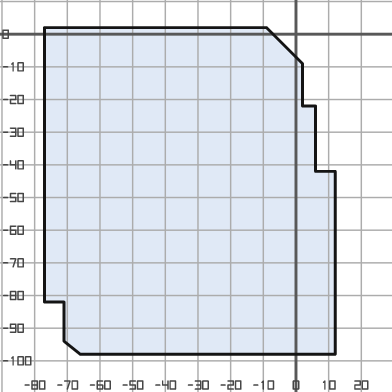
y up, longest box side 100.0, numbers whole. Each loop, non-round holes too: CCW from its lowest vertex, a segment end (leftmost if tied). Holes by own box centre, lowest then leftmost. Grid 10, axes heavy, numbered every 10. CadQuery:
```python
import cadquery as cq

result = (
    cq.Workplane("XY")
    .moveTo(-66.0, -98.0)
    .lineTo(12.0, -98.0)
    .lineTo(12.0, -42.0)
    .lineTo(6.0, -42.0)
    .lineTo(6.0, -22.0)
    .lineTo(2.0, -22.0)
    .lineTo(2.0, -9.0)
    .lineTo(-9.0, 2.0)
    .lineTo(-77.0, 2.0)
    .lineTo(-77.0, -82.0)
    .lineTo(-71.0, -82.0)
    .lineTo(-71.0, -94.0)
    .close()
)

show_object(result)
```